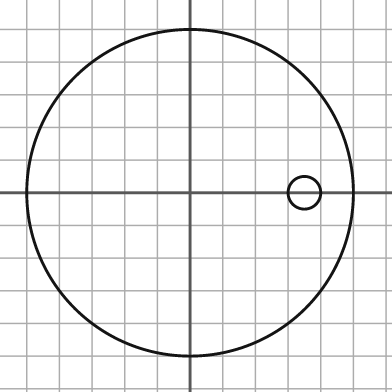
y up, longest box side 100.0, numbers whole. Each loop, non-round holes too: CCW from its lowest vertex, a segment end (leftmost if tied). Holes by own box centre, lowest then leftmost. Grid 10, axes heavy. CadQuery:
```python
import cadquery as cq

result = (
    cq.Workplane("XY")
    .moveTo(0.0, 0.0)
    .circle(50.0)
    .moveTo(35.0, 0.0)
    .circle(5.0)
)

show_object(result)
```